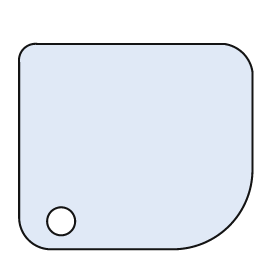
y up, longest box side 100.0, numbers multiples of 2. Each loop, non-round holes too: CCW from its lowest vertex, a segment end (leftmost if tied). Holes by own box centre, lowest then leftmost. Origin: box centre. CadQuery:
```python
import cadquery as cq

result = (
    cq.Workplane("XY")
    .moveTo(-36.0, -44.0)
    .lineTo(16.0, -44.0)
    .threePointArc((40.0, -34.0), (50.0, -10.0))
    .lineTo(50.0, 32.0)
    .threePointArc((46.0, 40.0), (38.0, 44.0))
    .lineTo(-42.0, 44.0)
    .threePointArc((-48.0, 42.0), (-50.0, 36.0))
    .lineTo(-50.0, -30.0)
    .threePointArc((-46.0, -40.0), (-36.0, -44.0))
    .close()
    .moveTo(-32.0, -32.0)
    .circle(6.0)
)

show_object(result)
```